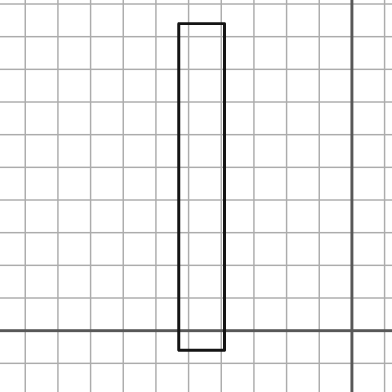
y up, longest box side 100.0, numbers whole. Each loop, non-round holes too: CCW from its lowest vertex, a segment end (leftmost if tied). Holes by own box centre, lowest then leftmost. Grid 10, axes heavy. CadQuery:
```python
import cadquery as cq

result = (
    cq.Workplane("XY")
    .moveTo(-53.0, -6.0)
    .lineTo(-39.0, -6.0)
    .lineTo(-39.0, 94.0)
    .lineTo(-53.0, 94.0)
    .close()
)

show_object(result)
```